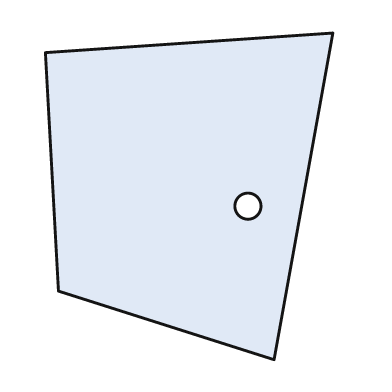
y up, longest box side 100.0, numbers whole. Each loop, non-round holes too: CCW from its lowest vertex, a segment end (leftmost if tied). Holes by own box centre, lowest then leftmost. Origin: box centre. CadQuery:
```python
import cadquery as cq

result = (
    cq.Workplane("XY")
    .moveTo(26.0, -50.0)
    .lineTo(44.0, 50.0)
    .lineTo(-44.0, 44.0)
    .lineTo(-40.0, -29.0)
    .close()
    .moveTo(18.0, -3.0)
    .circle(4.0)
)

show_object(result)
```